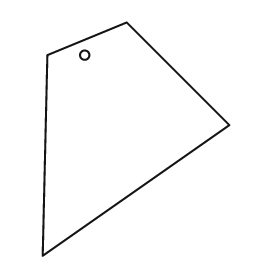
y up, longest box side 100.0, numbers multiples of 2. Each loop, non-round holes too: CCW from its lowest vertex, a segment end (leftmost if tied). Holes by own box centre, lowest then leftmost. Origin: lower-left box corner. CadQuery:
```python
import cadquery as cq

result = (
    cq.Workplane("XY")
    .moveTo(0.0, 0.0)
    .lineTo(80.0, 56.0)
    .lineTo(36.0, 100.0)
    .lineTo(2.0, 86.0)
    .close()
    .moveTo(18.0, 86.0)
    .circle(2.0)
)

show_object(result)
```